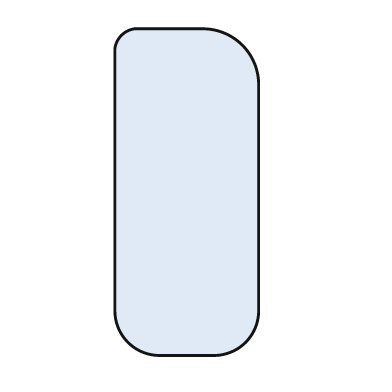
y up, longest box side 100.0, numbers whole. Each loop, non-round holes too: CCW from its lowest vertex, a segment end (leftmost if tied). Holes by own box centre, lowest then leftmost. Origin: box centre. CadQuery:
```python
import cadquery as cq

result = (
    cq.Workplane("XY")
    .moveTo(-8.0, -50.0)
    .lineTo(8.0, -50.0)
    .threePointArc((18.0, -46.0), (22.0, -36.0))
    .lineTo(22.0, 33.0)
    .threePointArc((17.0, 45.0), (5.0, 50.0))
    .lineTo(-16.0, 50.0)
    .threePointArc((-20.0, 48.0), (-22.0, 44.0))
    .lineTo(-22.0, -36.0)
    .threePointArc((-18.0, -46.0), (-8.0, -50.0))
    .close()
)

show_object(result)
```